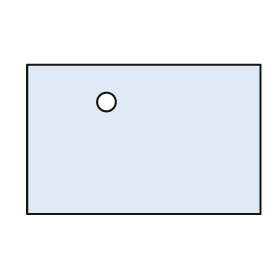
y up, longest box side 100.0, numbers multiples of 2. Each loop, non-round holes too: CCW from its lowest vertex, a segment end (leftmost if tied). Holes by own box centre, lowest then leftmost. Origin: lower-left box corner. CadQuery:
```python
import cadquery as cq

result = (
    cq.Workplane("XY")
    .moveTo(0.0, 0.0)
    .lineTo(100.0, 0.0)
    .lineTo(100.0, 64.0)
    .lineTo(0.0, 64.0)
    .close()
    .moveTo(34.0, 48.0)
    .circle(4.0)
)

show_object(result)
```